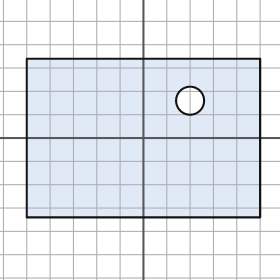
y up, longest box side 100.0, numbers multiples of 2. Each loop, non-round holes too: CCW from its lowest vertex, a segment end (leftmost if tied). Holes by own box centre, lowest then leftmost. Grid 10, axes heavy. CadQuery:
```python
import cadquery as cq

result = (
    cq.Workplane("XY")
    .moveTo(-50.0, -34.0)
    .lineTo(50.0, -34.0)
    .lineTo(50.0, 34.0)
    .lineTo(-50.0, 34.0)
    .close()
    .moveTo(20.0, 16.0)
    .circle(6.0)
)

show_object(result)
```